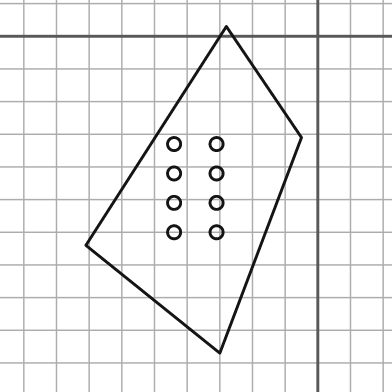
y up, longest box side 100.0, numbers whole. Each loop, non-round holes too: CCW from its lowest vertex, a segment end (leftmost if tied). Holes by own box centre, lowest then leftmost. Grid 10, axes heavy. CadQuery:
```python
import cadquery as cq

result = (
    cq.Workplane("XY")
    .moveTo(-30.0, -97.0)
    .lineTo(-5.0, -31.0)
    .lineTo(-28.0, 3.0)
    .lineTo(-71.0, -64.0)
    .close()
    .moveTo(-44.0, -60.0)
    .circle(2.0)
    .moveTo(-31.0, -60.0)
    .circle(2.0)
    .moveTo(-44.0, -51.0)
    .circle(2.0)
    .moveTo(-31.0, -51.0)
    .circle(2.0)
    .moveTo(-44.0, -42.0)
    .circle(2.0)
    .moveTo(-31.0, -42.0)
    .circle(2.0)
    .moveTo(-44.0, -33.0)
    .circle(2.0)
    .moveTo(-31.0, -33.0)
    .circle(2.0)
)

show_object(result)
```